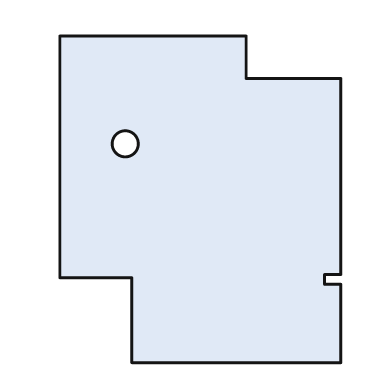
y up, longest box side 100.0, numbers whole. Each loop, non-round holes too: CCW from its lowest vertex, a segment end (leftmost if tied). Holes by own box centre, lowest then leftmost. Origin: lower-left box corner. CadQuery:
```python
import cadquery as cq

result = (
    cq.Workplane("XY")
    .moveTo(22.0, 0.0)
    .lineTo(86.0, 0.0)
    .lineTo(86.0, 24.0)
    .lineTo(81.0, 24.0)
    .lineTo(81.0, 27.0)
    .lineTo(86.0, 27.0)
    .lineTo(86.0, 87.0)
    .lineTo(57.0, 87.0)
    .lineTo(57.0, 100.0)
    .lineTo(0.0, 100.0)
    .lineTo(0.0, 26.0)
    .lineTo(22.0, 26.0)
    .close()
    .moveTo(20.0, 67.0)
    .circle(4.0)
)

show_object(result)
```